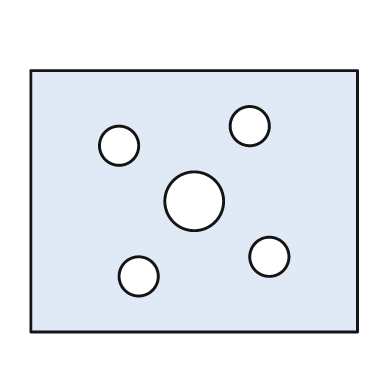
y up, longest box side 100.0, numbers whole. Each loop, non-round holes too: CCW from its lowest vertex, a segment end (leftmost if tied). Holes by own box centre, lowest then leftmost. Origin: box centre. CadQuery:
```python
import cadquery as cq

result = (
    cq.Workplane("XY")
    .moveTo(-50.0, -40.0)
    .lineTo(50.0, -40.0)
    .lineTo(50.0, 40.0)
    .lineTo(-50.0, 40.0)
    .close()
    .moveTo(-17.0, -23.0)
    .circle(6.0)
    .moveTo(23.0, -17.0)
    .circle(6.0)
    .moveTo(0.0, 0.0)
    .circle(9.0)
    .moveTo(-23.0, 17.0)
    .circle(6.0)
    .moveTo(17.0, 23.0)
    .circle(6.0)
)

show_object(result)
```